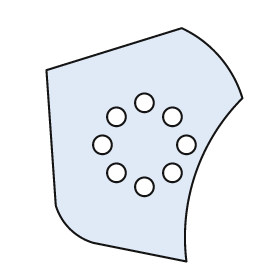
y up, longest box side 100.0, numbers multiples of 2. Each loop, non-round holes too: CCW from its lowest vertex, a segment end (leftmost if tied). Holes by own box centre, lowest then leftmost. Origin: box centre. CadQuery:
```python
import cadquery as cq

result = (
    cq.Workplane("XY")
    .moveTo(18.0, -50.0)
    .threePointArc((22.0, -12.0), (42.0, 20.0))
    .threePointArc((32.0, 38.0), (16.0, 50.0))
    .lineTo(-42.0, 32.0)
    .lineTo(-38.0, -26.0)
    .threePointArc((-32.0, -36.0), (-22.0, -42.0))
    .close()
    .moveTo(0.0, -18.0)
    .circle(4.0)
    .moveTo(-12.0, -12.0)
    .circle(4.0)
    .moveTo(12.0, -12.0)
    .circle(4.0)
    .moveTo(-18.0, 0.0)
    .circle(4.0)
    .moveTo(18.0, 0.0)
    .circle(4.0)
    .moveTo(-12.0, 12.0)
    .circle(4.0)
    .moveTo(12.0, 12.0)
    .circle(4.0)
    .moveTo(0.0, 18.0)
    .circle(4.0)
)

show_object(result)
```